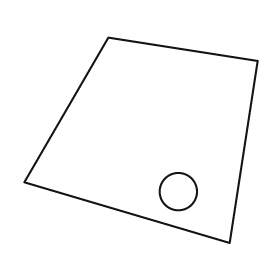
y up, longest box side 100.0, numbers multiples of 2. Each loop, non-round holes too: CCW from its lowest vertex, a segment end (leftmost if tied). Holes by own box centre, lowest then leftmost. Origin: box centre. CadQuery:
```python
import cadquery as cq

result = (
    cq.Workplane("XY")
    .moveTo(38.0, -44.0)
    .lineTo(50.0, 34.0)
    .lineTo(-14.0, 44.0)
    .lineTo(-50.0, -18.0)
    .close()
    .moveTo(16.0, -22.0)
    .circle(8.0)
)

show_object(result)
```